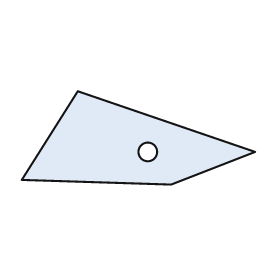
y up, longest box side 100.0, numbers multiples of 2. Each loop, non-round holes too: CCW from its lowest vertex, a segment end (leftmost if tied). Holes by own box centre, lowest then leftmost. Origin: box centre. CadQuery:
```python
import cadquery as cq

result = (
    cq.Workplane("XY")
    .moveTo(14.0, -20.0)
    .lineTo(50.0, -6.0)
    .lineTo(-26.0, 20.0)
    .lineTo(-50.0, -18.0)
    .close()
    .moveTo(4.0, -6.0)
    .circle(4.0)
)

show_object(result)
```